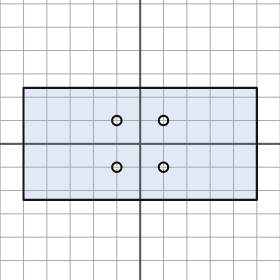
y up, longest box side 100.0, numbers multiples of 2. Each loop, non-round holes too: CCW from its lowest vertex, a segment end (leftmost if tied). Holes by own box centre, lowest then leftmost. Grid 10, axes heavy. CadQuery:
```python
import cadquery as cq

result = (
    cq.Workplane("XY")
    .moveTo(-50.0, -24.0)
    .lineTo(50.0, -24.0)
    .lineTo(50.0, 24.0)
    .lineTo(-50.0, 24.0)
    .close()
    .moveTo(-10.0, -10.0)
    .circle(2.0)
    .moveTo(10.0, -10.0)
    .circle(2.0)
    .moveTo(-10.0, 10.0)
    .circle(2.0)
    .moveTo(10.0, 10.0)
    .circle(2.0)
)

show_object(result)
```